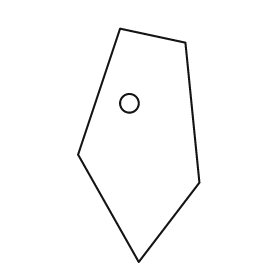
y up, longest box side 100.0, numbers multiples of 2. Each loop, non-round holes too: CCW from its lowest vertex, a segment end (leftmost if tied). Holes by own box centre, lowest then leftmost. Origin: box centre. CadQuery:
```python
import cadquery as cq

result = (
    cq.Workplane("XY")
    .moveTo(0.0, -50.0)
    .lineTo(26.0, -16.0)
    .lineTo(20.0, 44.0)
    .lineTo(-8.0, 50.0)
    .lineTo(-26.0, -4.0)
    .close()
    .moveTo(-4.0, 18.0)
    .circle(4.0)
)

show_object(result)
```